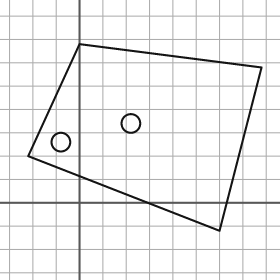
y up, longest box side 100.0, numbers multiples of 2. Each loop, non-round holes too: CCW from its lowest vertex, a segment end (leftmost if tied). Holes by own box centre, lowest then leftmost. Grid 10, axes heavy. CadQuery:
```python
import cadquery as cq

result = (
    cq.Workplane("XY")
    .moveTo(60.0, -12.0)
    .lineTo(78.0, 58.0)
    .lineTo(0.0, 68.0)
    .lineTo(-22.0, 20.0)
    .close()
    .moveTo(-8.0, 26.0)
    .circle(4.0)
    .moveTo(22.0, 34.0)
    .circle(4.0)
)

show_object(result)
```